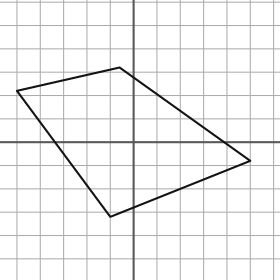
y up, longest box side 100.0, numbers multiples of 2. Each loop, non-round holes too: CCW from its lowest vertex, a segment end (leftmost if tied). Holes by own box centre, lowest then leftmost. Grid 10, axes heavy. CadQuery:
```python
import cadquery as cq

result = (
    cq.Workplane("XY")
    .moveTo(-10.0, -32.0)
    .lineTo(50.0, -8.0)
    .lineTo(-6.0, 32.0)
    .lineTo(-50.0, 22.0)
    .close()
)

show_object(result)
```